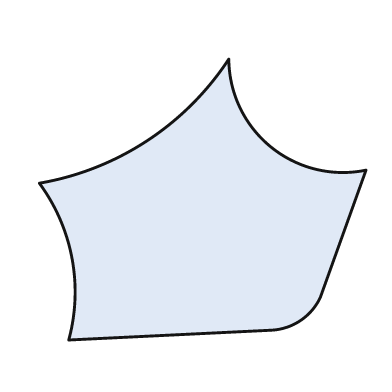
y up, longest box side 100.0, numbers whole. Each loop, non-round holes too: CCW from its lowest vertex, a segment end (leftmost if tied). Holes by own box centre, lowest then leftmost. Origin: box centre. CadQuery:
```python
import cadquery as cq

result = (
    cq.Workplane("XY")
    .moveTo(-41.0, -43.0)
    .lineTo(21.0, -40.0)
    .threePointArc((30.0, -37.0), (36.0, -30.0))
    .lineTo(50.0, 9.0)
    .threePointArc((21.0, 16.0), (8.0, 43.0))
    .threePointArc((-17.0, 18.0), (-50.0, 5.0))
    .threePointArc((-40.0, -18.0), (-41.0, -43.0))
    .close()
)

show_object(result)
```